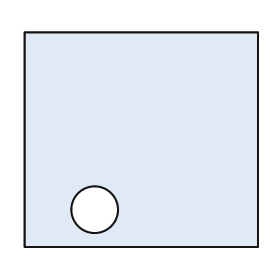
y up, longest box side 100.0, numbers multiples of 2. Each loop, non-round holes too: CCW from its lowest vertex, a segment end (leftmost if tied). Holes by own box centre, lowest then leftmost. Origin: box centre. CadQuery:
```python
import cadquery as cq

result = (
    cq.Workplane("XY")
    .moveTo(-50.0, -46.0)
    .lineTo(50.0, -46.0)
    .lineTo(50.0, 46.0)
    .lineTo(-50.0, 46.0)
    .close()
    .moveTo(-20.0, -30.0)
    .circle(10.0)
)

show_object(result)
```